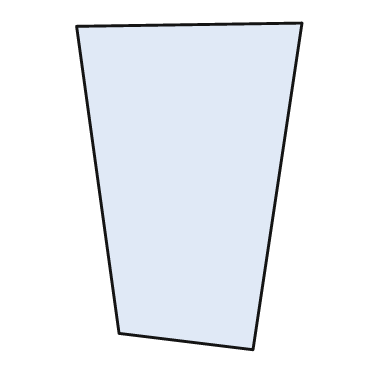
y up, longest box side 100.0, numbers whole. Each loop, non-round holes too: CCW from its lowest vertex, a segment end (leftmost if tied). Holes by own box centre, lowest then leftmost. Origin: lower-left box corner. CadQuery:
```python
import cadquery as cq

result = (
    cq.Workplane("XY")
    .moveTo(54.0, 0.0)
    .lineTo(69.0, 100.0)
    .lineTo(0.0, 99.0)
    .lineTo(13.0, 5.0)
    .close()
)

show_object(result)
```